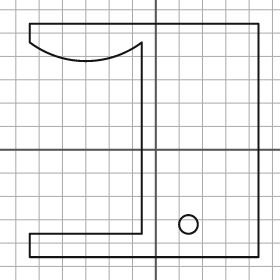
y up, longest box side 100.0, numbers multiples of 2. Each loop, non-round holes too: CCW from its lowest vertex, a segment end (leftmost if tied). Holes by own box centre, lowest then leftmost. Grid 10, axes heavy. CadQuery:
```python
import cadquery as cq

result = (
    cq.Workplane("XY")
    .moveTo(-54.0, -46.0)
    .lineTo(44.0, -46.0)
    .lineTo(44.0, 54.0)
    .lineTo(-54.0, 54.0)
    .lineTo(-54.0, 46.0)
    .threePointArc((-30.0, 38.0), (-6.0, 46.0))
    .lineTo(-6.0, -36.0)
    .lineTo(-54.0, -36.0)
    .close()
    .moveTo(14.0, -32.0)
    .circle(4.0)
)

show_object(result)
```